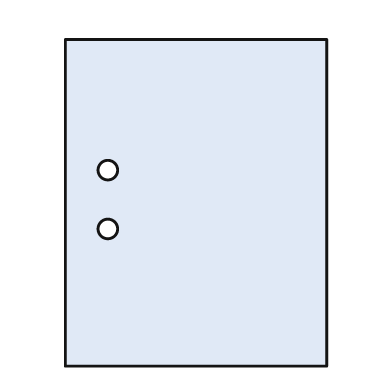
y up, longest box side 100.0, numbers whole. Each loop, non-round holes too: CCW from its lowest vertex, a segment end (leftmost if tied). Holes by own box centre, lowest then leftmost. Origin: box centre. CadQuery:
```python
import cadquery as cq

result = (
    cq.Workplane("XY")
    .moveTo(-40.0, -50.0)
    .lineTo(40.0, -50.0)
    .lineTo(40.0, 50.0)
    .lineTo(-40.0, 50.0)
    .close()
    .moveTo(-27.0, -8.0)
    .circle(3.0)
    .moveTo(-27.0, 10.0)
    .circle(3.0)
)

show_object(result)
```